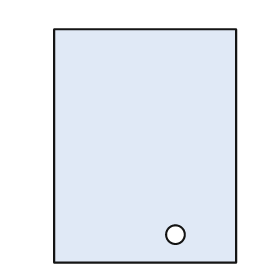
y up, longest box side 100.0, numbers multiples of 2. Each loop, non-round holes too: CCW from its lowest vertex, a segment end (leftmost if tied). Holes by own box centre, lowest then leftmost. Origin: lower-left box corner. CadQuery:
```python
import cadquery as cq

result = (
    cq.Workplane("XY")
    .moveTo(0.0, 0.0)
    .lineTo(78.0, 0.0)
    .lineTo(78.0, 100.0)
    .lineTo(0.0, 100.0)
    .close()
    .moveTo(52.0, 12.0)
    .circle(4.0)
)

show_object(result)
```